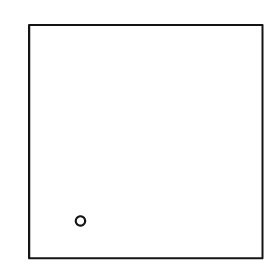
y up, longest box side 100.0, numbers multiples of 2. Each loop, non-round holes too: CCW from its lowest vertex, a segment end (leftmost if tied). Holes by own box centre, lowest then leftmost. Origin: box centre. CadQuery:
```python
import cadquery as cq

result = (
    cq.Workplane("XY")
    .moveTo(-50.0, -50.0)
    .lineTo(50.0, -50.0)
    .lineTo(50.0, 50.0)
    .lineTo(-50.0, 50.0)
    .close()
    .moveTo(-28.0, -34.0)
    .circle(2.0)
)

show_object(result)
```